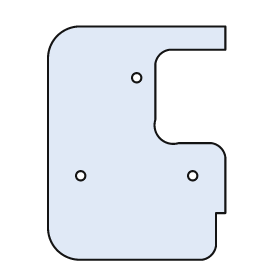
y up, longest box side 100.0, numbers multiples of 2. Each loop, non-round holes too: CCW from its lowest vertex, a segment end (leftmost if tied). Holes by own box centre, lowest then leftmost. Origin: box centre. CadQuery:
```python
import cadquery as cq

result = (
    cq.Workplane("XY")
    .moveTo(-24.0, -50.0)
    .lineTo(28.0, -50.0)
    .threePointArc((32.0, -48.0), (34.0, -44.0))
    .lineTo(34.0, -30.0)
    .lineTo(38.0, -30.0)
    .lineTo(38.0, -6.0)
    .threePointArc((36.0, -2.0), (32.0, 0.0))
    .lineTo(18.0, 0.0)
    .threePointArc((10.0, 2.0), (8.0, 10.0))
    .lineTo(8.0, 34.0)
    .threePointArc((10.0, 38.0), (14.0, 40.0))
    .lineTo(38.0, 40.0)
    .lineTo(38.0, 50.0)
    .lineTo(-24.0, 50.0)
    .threePointArc((-34.0, 46.0), (-38.0, 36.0))
    .lineTo(-38.0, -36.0)
    .threePointArc((-34.0, -46.0), (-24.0, -50.0))
    .close()
    .moveTo(-24.0, -14.0)
    .circle(2.0)
    .moveTo(24.0, -14.0)
    .circle(2.0)
    .moveTo(0.0, 28.0)
    .circle(2.0)
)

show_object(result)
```